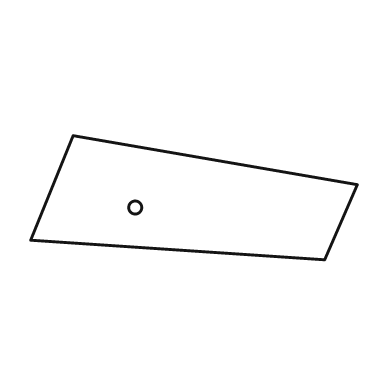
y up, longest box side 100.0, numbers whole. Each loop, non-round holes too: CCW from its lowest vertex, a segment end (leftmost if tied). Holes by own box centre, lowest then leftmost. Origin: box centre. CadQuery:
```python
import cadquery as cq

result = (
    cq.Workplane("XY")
    .moveTo(40.0, -19.0)
    .lineTo(50.0, 4.0)
    .lineTo(-37.0, 19.0)
    .lineTo(-50.0, -13.0)
    .close()
    .moveTo(-18.0, -3.0)
    .circle(2.0)
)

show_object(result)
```